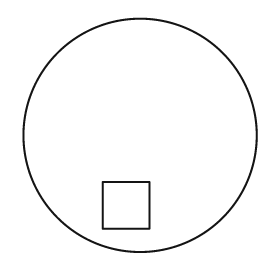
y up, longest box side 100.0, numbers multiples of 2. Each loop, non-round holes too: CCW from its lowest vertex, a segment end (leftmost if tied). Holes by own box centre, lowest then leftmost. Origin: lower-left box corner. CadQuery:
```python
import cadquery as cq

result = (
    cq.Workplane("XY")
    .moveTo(50.0, 50.0)
    .circle(50.0)
    .moveTo(34.0, 10.0)
    .lineTo(54.0, 10.0)
    .lineTo(54.0, 30.0)
    .lineTo(34.0, 30.0)
    .close()
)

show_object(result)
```